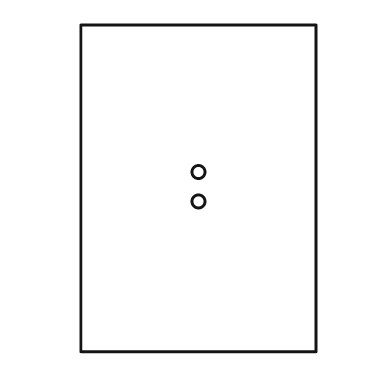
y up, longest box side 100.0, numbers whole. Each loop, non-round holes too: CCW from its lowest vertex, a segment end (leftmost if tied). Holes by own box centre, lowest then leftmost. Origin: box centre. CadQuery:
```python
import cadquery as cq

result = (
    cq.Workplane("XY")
    .moveTo(-36.0, -50.0)
    .lineTo(36.0, -50.0)
    .lineTo(36.0, 50.0)
    .lineTo(-36.0, 50.0)
    .close()
    .moveTo(0.0, -4.0)
    .circle(2.0)
    .moveTo(0.0, 5.0)
    .circle(2.0)
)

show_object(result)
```